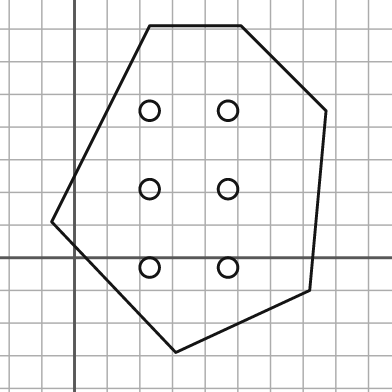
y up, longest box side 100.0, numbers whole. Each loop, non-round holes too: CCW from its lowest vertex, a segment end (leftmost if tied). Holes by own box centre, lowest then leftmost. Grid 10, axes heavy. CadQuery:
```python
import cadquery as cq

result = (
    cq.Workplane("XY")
    .moveTo(31.0, -29.0)
    .lineTo(72.0, -10.0)
    .lineTo(77.0, 45.0)
    .lineTo(51.0, 71.0)
    .lineTo(23.0, 71.0)
    .lineTo(-7.0, 11.0)
    .close()
    .moveTo(23.0, -3.0)
    .circle(3.0)
    .moveTo(47.0, -3.0)
    .circle(3.0)
    .moveTo(23.0, 21.0)
    .circle(3.0)
    .moveTo(47.0, 21.0)
    .circle(3.0)
    .moveTo(23.0, 45.0)
    .circle(3.0)
    .moveTo(47.0, 45.0)
    .circle(3.0)
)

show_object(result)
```